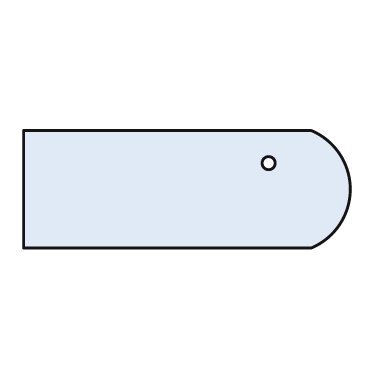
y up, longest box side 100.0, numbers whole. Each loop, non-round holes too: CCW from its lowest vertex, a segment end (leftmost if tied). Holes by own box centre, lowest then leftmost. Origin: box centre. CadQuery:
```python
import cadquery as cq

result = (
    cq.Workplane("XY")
    .moveTo(-50.0, -18.0)
    .lineTo(38.0, -18.0)
    .threePointArc((50.0, 0.0), (38.0, 18.0))
    .lineTo(-50.0, 18.0)
    .close()
    .moveTo(25.0, 8.0)
    .circle(2.0)
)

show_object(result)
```